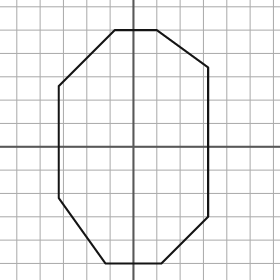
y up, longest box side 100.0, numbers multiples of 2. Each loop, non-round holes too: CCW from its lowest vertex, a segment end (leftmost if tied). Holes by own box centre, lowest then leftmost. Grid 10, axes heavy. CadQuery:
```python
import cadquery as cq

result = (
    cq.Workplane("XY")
    .moveTo(-12.0, -50.0)
    .lineTo(12.0, -50.0)
    .lineTo(32.0, -30.0)
    .lineTo(32.0, 34.0)
    .lineTo(10.0, 50.0)
    .lineTo(-8.0, 50.0)
    .lineTo(-32.0, 26.0)
    .lineTo(-32.0, -22.0)
    .close()
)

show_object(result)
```